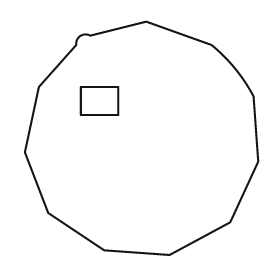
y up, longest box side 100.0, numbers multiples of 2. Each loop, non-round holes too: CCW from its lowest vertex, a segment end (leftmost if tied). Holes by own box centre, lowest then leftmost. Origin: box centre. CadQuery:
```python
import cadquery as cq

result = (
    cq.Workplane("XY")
    .moveTo(12.0, -50.0)
    .lineTo(38.0, -36.0)
    .lineTo(50.0, -10.0)
    .lineTo(48.0, 18.0)
    .threePointArc((40.0, 30.0), (30.0, 40.0))
    .lineTo(2.0, 50.0)
    .lineTo(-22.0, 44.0)
    .threePointArc((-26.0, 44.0), (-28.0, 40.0))
    .lineTo(-44.0, 22.0)
    .lineTo(-50.0, -6.0)
    .lineTo(-40.0, -32.0)
    .lineTo(-16.0, -48.0)
    .close()
    .moveTo(-26.0, 10.0)
    .lineTo(-10.0, 10.0)
    .lineTo(-10.0, 22.0)
    .lineTo(-26.0, 22.0)
    .close()
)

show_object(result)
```